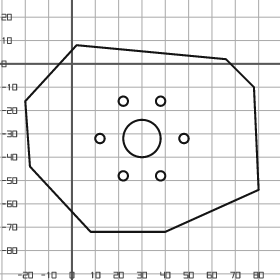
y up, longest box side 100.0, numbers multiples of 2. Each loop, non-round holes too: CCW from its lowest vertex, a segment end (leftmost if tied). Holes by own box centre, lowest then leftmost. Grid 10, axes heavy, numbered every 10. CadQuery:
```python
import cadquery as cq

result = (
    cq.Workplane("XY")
    .moveTo(8.0, -72.0)
    .lineTo(40.0, -72.0)
    .lineTo(80.0, -54.0)
    .lineTo(78.0, -10.0)
    .lineTo(66.0, 2.0)
    .lineTo(2.0, 8.0)
    .lineTo(-20.0, -16.0)
    .lineTo(-18.0, -44.0)
    .close()
    .moveTo(22.0, -48.0)
    .circle(2.0)
    .moveTo(38.0, -48.0)
    .circle(2.0)
    .moveTo(12.0, -32.0)
    .circle(2.0)
    .moveTo(30.0, -32.0)
    .circle(8.0)
    .moveTo(48.0, -32.0)
    .circle(2.0)
    .moveTo(22.0, -16.0)
    .circle(2.0)
    .moveTo(38.0, -16.0)
    .circle(2.0)
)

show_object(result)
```